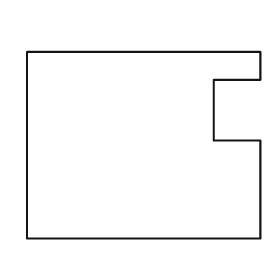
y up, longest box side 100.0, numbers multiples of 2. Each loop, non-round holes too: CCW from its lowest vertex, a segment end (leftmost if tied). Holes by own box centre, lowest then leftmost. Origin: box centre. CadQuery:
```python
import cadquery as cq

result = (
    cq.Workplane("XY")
    .moveTo(-50.0, -40.0)
    .lineTo(50.0, -40.0)
    .lineTo(50.0, 2.0)
    .lineTo(30.0, 2.0)
    .lineTo(30.0, 28.0)
    .lineTo(50.0, 28.0)
    .lineTo(50.0, 40.0)
    .lineTo(-50.0, 40.0)
    .close()
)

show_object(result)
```